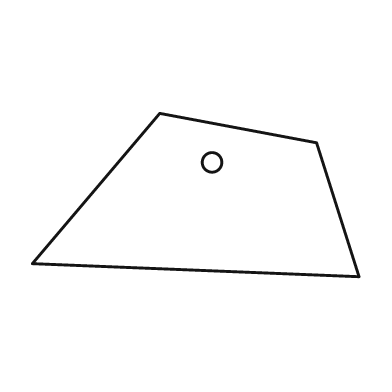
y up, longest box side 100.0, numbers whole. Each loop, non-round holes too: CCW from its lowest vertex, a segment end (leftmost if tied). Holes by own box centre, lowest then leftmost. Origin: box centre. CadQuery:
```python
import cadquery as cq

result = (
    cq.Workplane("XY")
    .moveTo(50.0, -25.0)
    .lineTo(37.0, 16.0)
    .lineTo(-11.0, 25.0)
    .lineTo(-50.0, -21.0)
    .close()
    .moveTo(5.0, 10.0)
    .circle(3.0)
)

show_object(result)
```